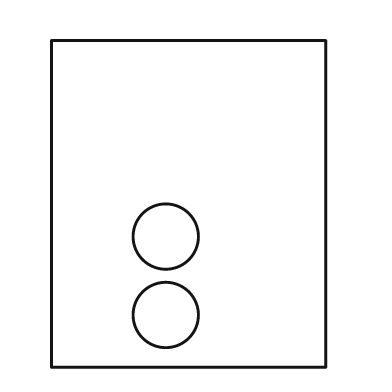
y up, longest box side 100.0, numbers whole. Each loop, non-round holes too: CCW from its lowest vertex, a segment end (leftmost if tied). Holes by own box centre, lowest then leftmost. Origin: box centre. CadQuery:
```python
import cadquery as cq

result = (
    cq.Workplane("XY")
    .moveTo(-42.0, -50.0)
    .lineTo(42.0, -50.0)
    .lineTo(42.0, 50.0)
    .lineTo(-42.0, 50.0)
    .close()
    .moveTo(-7.0, -34.0)
    .circle(10.0)
    .moveTo(-7.0, -10.0)
    .circle(10.0)
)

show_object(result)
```